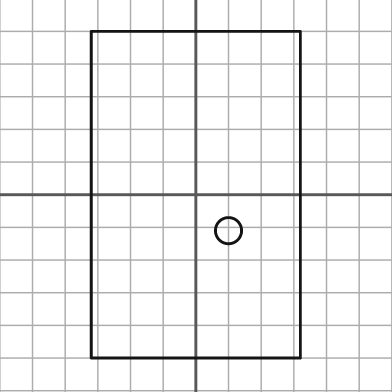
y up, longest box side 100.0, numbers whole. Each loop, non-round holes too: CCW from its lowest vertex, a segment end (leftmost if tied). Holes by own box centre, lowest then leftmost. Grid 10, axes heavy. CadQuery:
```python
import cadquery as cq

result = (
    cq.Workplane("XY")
    .moveTo(-32.0, -50.0)
    .lineTo(32.0, -50.0)
    .lineTo(32.0, 50.0)
    .lineTo(-32.0, 50.0)
    .close()
    .moveTo(10.0, -11.0)
    .circle(4.0)
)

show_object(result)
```